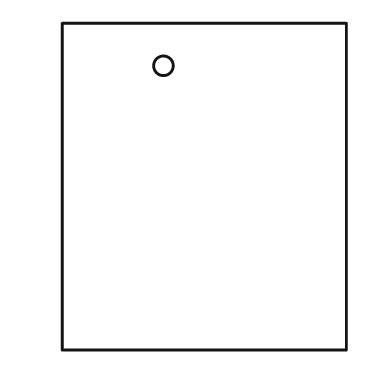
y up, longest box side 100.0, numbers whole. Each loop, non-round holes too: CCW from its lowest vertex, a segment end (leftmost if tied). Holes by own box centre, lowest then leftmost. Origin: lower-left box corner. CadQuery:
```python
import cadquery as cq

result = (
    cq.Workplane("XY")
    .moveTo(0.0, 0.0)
    .lineTo(87.0, 0.0)
    .lineTo(87.0, 100.0)
    .lineTo(0.0, 100.0)
    .close()
    .moveTo(31.0, 87.0)
    .circle(3.0)
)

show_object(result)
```